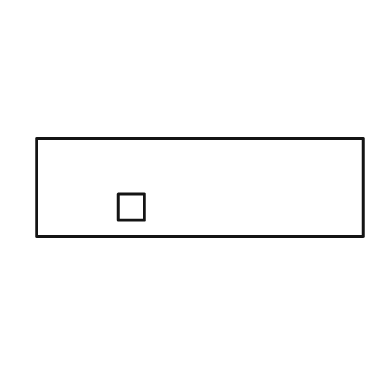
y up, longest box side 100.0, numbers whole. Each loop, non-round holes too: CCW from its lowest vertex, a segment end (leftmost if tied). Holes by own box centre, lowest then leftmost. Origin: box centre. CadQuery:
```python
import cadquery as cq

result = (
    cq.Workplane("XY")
    .moveTo(-50.0, -15.0)
    .lineTo(50.0, -15.0)
    .lineTo(50.0, 15.0)
    .lineTo(-50.0, 15.0)
    .close()
    .moveTo(-25.0, -10.0)
    .lineTo(-17.0, -10.0)
    .lineTo(-17.0, -2.0)
    .lineTo(-25.0, -2.0)
    .close()
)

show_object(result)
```